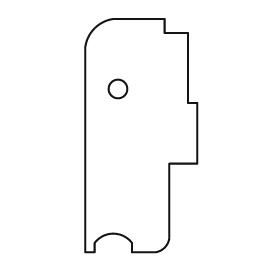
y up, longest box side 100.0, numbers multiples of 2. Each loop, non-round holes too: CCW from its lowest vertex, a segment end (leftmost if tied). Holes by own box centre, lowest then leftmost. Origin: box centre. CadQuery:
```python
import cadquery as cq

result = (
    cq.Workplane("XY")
    .moveTo(-24.0, -50.0)
    .lineTo(-20.0, -50.0)
    .lineTo(-20.0, -46.0)
    .threePointArc((-12.0, -42.0), (-4.0, -46.0))
    .lineTo(-4.0, -50.0)
    .lineTo(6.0, -50.0)
    .threePointArc((10.0, -48.0), (12.0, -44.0))
    .lineTo(12.0, -12.0)
    .lineTo(24.0, -12.0)
    .lineTo(24.0, 14.0)
    .lineTo(20.0, 14.0)
    .lineTo(20.0, 44.0)
    .lineTo(10.0, 44.0)
    .lineTo(10.0, 50.0)
    .lineTo(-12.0, 50.0)
    .threePointArc((-20.0, 46.0), (-24.0, 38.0))
    .close()
    .moveTo(-10.0, 20.0)
    .circle(4.0)
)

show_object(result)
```